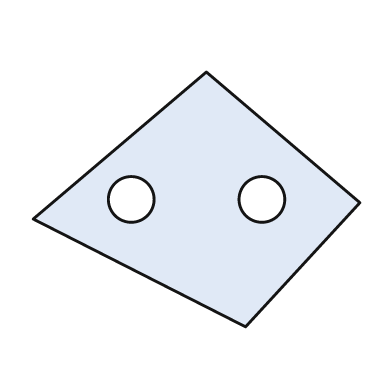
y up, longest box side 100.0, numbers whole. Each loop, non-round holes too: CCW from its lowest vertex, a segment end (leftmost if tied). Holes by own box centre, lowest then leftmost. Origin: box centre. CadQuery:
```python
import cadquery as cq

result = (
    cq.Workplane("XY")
    .moveTo(15.0, -39.0)
    .lineTo(50.0, -1.0)
    .lineTo(3.0, 39.0)
    .lineTo(-50.0, -6.0)
    .close()
    .moveTo(-20.0, 0.0)
    .circle(7.0)
    .moveTo(20.0, 0.0)
    .circle(7.0)
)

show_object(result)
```